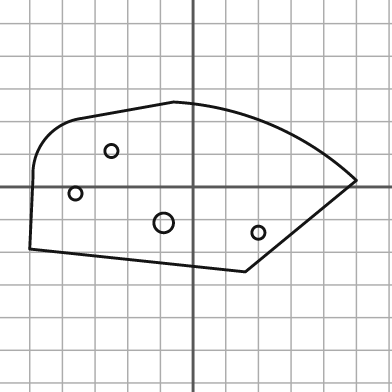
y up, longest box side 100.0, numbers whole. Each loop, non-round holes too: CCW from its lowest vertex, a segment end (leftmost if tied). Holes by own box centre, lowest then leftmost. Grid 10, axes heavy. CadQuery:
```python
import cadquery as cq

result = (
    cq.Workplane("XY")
    .moveTo(16.0, -26.0)
    .lineTo(50.0, 2.0)
    .threePointArc((24.0, 19.0), (-6.0, 26.0))
    .lineTo(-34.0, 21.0)
    .threePointArc((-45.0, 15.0), (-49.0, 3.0))
    .lineTo(-50.0, -19.0)
    .close()
    .moveTo(20.0, -14.0)
    .circle(2.0)
    .moveTo(-9.0, -11.0)
    .circle(3.0)
    .moveTo(-36.0, -2.0)
    .circle(2.0)
    .moveTo(-25.0, 11.0)
    .circle(2.0)
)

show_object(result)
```